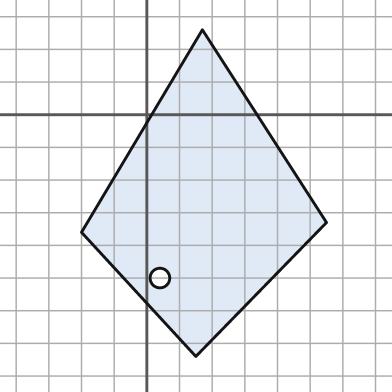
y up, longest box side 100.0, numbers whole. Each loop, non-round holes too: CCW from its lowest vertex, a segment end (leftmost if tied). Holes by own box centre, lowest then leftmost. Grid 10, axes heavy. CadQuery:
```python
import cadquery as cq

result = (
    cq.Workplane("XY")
    .moveTo(15.0, -74.0)
    .lineTo(55.0, -33.0)
    .lineTo(17.0, 26.0)
    .lineTo(-20.0, -36.0)
    .close()
    .moveTo(4.0, -50.0)
    .circle(3.0)
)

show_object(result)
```